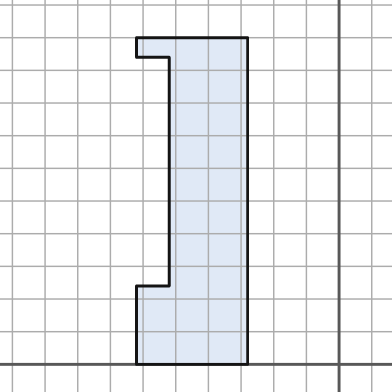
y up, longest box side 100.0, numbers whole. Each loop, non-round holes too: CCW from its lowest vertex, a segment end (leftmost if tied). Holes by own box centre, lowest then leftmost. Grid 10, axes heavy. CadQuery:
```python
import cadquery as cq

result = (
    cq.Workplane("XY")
    .moveTo(-62.0, 0.0)
    .lineTo(-28.0, 0.0)
    .lineTo(-28.0, 100.0)
    .lineTo(-62.0, 100.0)
    .lineTo(-62.0, 94.0)
    .lineTo(-52.0, 94.0)
    .lineTo(-52.0, 24.0)
    .lineTo(-62.0, 24.0)
    .close()
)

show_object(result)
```